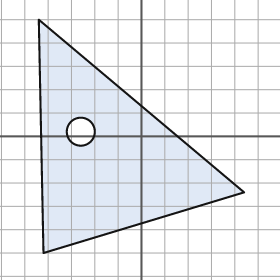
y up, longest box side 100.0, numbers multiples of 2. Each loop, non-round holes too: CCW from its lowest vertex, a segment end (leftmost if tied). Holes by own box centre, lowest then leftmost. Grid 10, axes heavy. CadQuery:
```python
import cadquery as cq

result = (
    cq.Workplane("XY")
    .moveTo(-42.0, -50.0)
    .lineTo(44.0, -24.0)
    .lineTo(-44.0, 50.0)
    .close()
    .moveTo(-26.0, 2.0)
    .circle(6.0)
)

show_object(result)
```